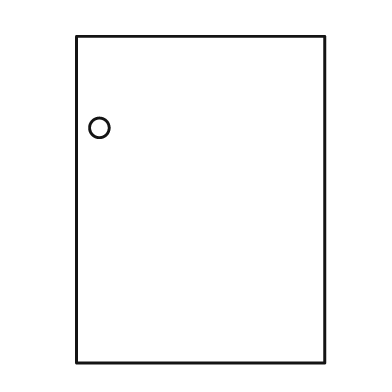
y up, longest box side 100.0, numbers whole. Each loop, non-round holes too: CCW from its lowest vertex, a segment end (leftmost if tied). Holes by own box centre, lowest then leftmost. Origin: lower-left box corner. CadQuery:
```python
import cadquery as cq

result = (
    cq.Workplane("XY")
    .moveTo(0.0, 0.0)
    .lineTo(76.0, 0.0)
    .lineTo(76.0, 100.0)
    .lineTo(0.0, 100.0)
    .close()
    .moveTo(7.0, 72.0)
    .circle(3.0)
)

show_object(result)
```